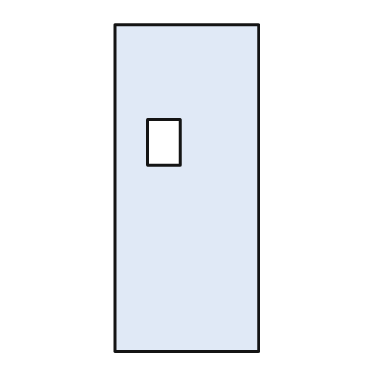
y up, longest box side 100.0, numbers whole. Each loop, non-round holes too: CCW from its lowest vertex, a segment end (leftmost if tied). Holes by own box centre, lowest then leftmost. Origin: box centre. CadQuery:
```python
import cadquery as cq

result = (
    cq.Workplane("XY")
    .moveTo(-22.0, -50.0)
    .lineTo(22.0, -50.0)
    .lineTo(22.0, 50.0)
    .lineTo(-22.0, 50.0)
    .close()
    .moveTo(-12.0, 7.0)
    .lineTo(-2.0, 7.0)
    .lineTo(-2.0, 21.0)
    .lineTo(-12.0, 21.0)
    .close()
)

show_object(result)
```